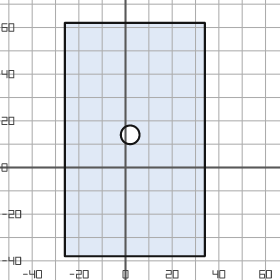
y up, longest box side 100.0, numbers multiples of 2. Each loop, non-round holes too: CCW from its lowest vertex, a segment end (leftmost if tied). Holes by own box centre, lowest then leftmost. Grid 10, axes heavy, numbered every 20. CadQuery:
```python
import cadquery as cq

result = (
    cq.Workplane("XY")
    .moveTo(-26.0, -38.0)
    .lineTo(34.0, -38.0)
    .lineTo(34.0, 62.0)
    .lineTo(-26.0, 62.0)
    .close()
    .moveTo(2.0, 14.0)
    .circle(4.0)
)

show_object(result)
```